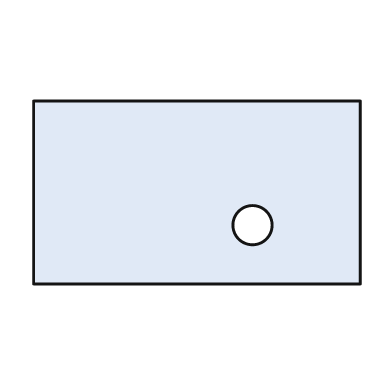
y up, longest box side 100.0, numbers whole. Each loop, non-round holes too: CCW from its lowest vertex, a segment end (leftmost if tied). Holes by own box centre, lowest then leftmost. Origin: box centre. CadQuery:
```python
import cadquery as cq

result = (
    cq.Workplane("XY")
    .moveTo(-50.0, -28.0)
    .lineTo(50.0, -28.0)
    .lineTo(50.0, 28.0)
    .lineTo(-50.0, 28.0)
    .close()
    .moveTo(17.0, -10.0)
    .circle(6.0)
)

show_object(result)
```